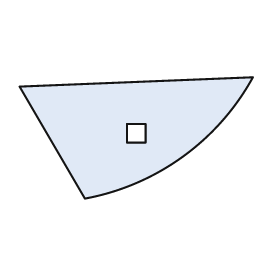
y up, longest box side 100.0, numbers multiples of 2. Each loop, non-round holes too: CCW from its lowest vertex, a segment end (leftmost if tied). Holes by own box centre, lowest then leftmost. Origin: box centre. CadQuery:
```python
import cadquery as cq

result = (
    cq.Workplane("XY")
    .moveTo(-22.0, -26.0)
    .threePointArc((20.0, -8.0), (50.0, 26.0))
    .lineTo(-50.0, 22.0)
    .close()
    .moveTo(-4.0, -2.0)
    .lineTo(4.0, -2.0)
    .lineTo(4.0, 6.0)
    .lineTo(-4.0, 6.0)
    .close()
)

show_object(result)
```